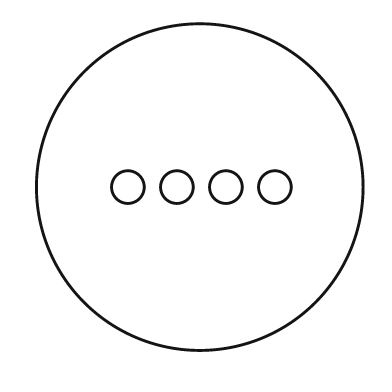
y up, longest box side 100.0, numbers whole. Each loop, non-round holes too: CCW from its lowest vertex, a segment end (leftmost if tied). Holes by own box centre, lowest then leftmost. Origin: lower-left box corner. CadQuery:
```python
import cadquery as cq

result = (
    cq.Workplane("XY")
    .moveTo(50.0, 50.0)
    .circle(50.0)
    .moveTo(28.0, 50.0)
    .circle(5.0)
    .moveTo(43.0, 50.0)
    .circle(5.0)
    .moveTo(58.0, 50.0)
    .circle(5.0)
    .moveTo(73.0, 50.0)
    .circle(5.0)
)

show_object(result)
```